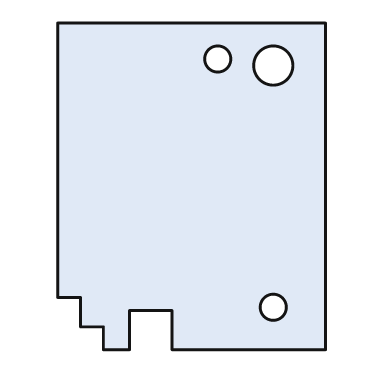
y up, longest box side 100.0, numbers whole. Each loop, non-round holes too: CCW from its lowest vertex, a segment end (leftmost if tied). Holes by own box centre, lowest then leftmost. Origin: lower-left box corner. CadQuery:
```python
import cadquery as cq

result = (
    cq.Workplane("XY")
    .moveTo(14.0, 0.0)
    .lineTo(22.0, 0.0)
    .lineTo(22.0, 12.0)
    .lineTo(35.0, 12.0)
    .lineTo(35.0, 0.0)
    .lineTo(82.0, 0.0)
    .lineTo(82.0, 100.0)
    .lineTo(0.0, 100.0)
    .lineTo(0.0, 16.0)
    .lineTo(7.0, 16.0)
    .lineTo(7.0, 7.0)
    .lineTo(14.0, 7.0)
    .close()
    .moveTo(66.0, 13.0)
    .circle(4.0)
    .moveTo(66.0, 87.0)
    .circle(6.0)
    .moveTo(49.0, 89.0)
    .circle(4.0)
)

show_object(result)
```